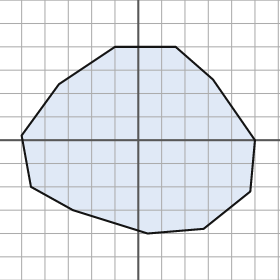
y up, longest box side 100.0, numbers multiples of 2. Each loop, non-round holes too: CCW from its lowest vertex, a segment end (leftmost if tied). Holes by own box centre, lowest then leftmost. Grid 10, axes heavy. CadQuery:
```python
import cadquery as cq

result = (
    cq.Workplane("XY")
    .moveTo(4.0, -40.0)
    .lineTo(28.0, -38.0)
    .lineTo(48.0, -22.0)
    .lineTo(50.0, 0.0)
    .lineTo(32.0, 26.0)
    .lineTo(16.0, 40.0)
    .lineTo(-10.0, 40.0)
    .lineTo(-34.0, 24.0)
    .lineTo(-50.0, 2.0)
    .lineTo(-46.0, -20.0)
    .lineTo(-28.0, -30.0)
    .close()
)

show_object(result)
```